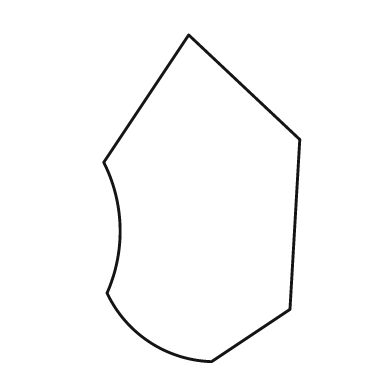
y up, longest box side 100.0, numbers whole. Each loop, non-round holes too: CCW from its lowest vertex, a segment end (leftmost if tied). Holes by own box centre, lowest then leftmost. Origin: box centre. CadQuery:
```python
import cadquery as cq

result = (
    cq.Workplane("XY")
    .moveTo(3.0, -50.0)
    .lineTo(27.0, -34.0)
    .lineTo(30.0, 18.0)
    .lineTo(-4.0, 50.0)
    .lineTo(-30.0, 11.0)
    .threePointArc((-25.0, -9.0), (-29.0, -29.0))
    .threePointArc((-16.0, -44.0), (3.0, -50.0))
    .close()
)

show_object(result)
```